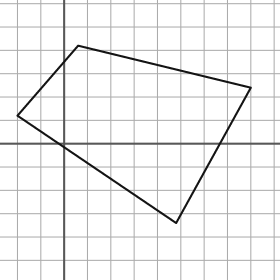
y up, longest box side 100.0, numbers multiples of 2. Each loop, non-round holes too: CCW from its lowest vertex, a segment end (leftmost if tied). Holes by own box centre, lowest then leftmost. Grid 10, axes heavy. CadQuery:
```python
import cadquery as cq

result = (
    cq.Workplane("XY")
    .moveTo(48.0, -34.0)
    .lineTo(80.0, 24.0)
    .lineTo(6.0, 42.0)
    .lineTo(-20.0, 12.0)
    .close()
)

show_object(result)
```